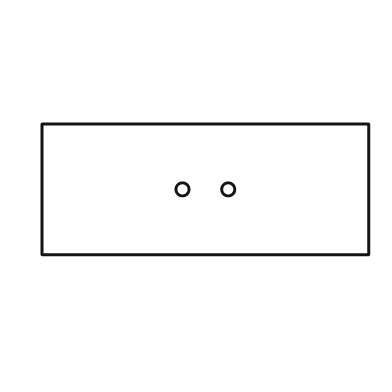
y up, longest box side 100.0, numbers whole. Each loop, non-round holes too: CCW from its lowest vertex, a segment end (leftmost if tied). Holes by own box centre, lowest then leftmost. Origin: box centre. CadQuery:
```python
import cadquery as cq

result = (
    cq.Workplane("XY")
    .moveTo(-50.0, -20.0)
    .lineTo(50.0, -20.0)
    .lineTo(50.0, 20.0)
    .lineTo(-50.0, 20.0)
    .close()
    .moveTo(-7.0, 0.0)
    .circle(2.0)
    .moveTo(7.0, 0.0)
    .circle(2.0)
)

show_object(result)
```